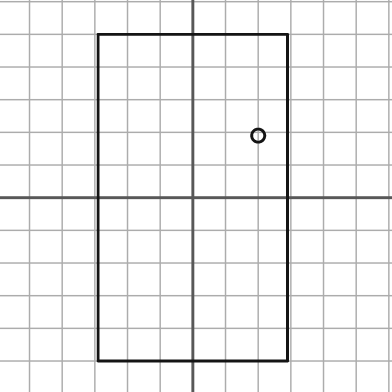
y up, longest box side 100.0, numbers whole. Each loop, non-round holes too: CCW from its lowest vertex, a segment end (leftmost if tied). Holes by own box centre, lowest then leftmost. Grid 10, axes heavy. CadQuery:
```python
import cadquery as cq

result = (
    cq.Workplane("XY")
    .moveTo(-29.0, -50.0)
    .lineTo(29.0, -50.0)
    .lineTo(29.0, 50.0)
    .lineTo(-29.0, 50.0)
    .close()
    .moveTo(20.0, 19.0)
    .circle(2.0)
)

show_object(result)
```